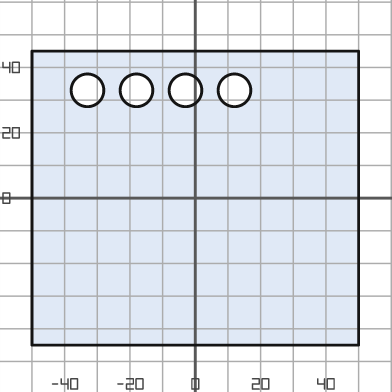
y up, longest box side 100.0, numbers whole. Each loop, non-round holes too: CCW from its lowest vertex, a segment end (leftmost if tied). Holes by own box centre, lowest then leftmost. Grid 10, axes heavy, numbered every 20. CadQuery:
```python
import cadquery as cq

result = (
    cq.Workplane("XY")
    .moveTo(-50.0, -45.0)
    .lineTo(50.0, -45.0)
    .lineTo(50.0, 45.0)
    .lineTo(-50.0, 45.0)
    .close()
    .moveTo(-33.0, 33.0)
    .circle(5.0)
    .moveTo(-18.0, 33.0)
    .circle(5.0)
    .moveTo(-3.0, 33.0)
    .circle(5.0)
    .moveTo(12.0, 33.0)
    .circle(5.0)
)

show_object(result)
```